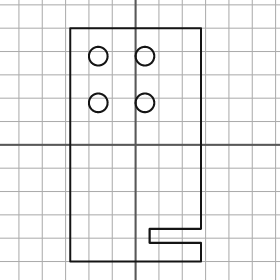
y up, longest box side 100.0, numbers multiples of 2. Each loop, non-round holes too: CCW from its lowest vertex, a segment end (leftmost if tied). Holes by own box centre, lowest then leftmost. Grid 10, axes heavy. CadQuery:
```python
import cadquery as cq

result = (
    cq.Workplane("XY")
    .moveTo(-28.0, -50.0)
    .lineTo(28.0, -50.0)
    .lineTo(28.0, -42.0)
    .lineTo(6.0, -42.0)
    .lineTo(6.0, -36.0)
    .lineTo(28.0, -36.0)
    .lineTo(28.0, 50.0)
    .lineTo(-28.0, 50.0)
    .close()
    .moveTo(-16.0, 18.0)
    .circle(4.0)
    .moveTo(4.0, 18.0)
    .circle(4.0)
    .moveTo(-16.0, 38.0)
    .circle(4.0)
    .moveTo(4.0, 38.0)
    .circle(4.0)
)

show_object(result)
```